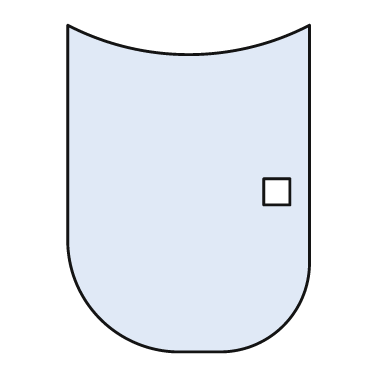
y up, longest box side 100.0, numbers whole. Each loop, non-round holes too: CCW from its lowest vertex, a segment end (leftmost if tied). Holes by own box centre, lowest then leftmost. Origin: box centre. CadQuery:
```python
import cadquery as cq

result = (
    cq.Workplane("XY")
    .moveTo(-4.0, -50.0)
    .lineTo(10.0, -50.0)
    .threePointArc((29.0, -42.0), (37.0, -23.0))
    .lineTo(37.0, 50.0)
    .threePointArc((0.0, 41.0), (-37.0, 50.0))
    .lineTo(-37.0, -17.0)
    .threePointArc((-27.0, -40.0), (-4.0, -50.0))
    .close()
    .moveTo(23.0, -5.0)
    .lineTo(31.0, -5.0)
    .lineTo(31.0, 3.0)
    .lineTo(23.0, 3.0)
    .close()
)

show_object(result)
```